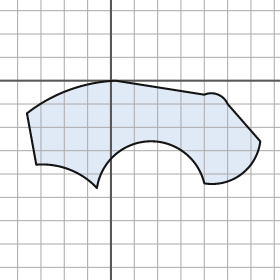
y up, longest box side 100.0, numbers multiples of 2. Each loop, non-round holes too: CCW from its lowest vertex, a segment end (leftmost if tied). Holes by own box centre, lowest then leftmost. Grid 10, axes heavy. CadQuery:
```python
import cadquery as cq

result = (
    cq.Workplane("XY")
    .moveTo(-6.0, -46.0)
    .threePointArc((16.0, -26.0), (40.0, -44.0))
    .threePointArc((56.0, -40.0), (64.0, -26.0))
    .lineTo(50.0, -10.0)
    .threePointArc((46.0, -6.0), (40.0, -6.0))
    .lineTo(2.0, 0.0)
    .threePointArc((-18.0, -4.0), (-36.0, -14.0))
    .lineTo(-32.0, -36.0)
    .threePointArc((-18.0, -38.0), (-6.0, -46.0))
    .close()
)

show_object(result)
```